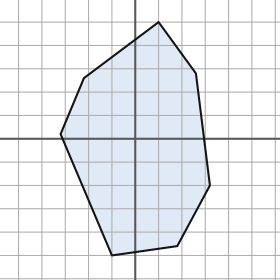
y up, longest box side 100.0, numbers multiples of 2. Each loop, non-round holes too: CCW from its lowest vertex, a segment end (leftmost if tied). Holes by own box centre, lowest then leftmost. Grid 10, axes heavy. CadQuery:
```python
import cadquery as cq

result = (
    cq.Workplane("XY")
    .moveTo(-10.0, -50.0)
    .lineTo(18.0, -46.0)
    .lineTo(32.0, -20.0)
    .lineTo(26.0, 28.0)
    .lineTo(10.0, 50.0)
    .lineTo(-22.0, 26.0)
    .lineTo(-32.0, 2.0)
    .close()
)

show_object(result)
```